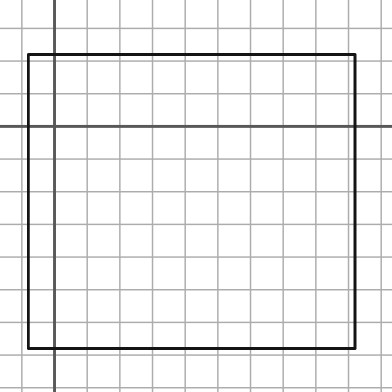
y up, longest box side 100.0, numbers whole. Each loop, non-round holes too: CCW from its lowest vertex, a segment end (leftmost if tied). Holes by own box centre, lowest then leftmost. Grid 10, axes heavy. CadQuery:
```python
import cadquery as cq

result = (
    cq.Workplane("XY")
    .moveTo(-8.0, -68.0)
    .lineTo(92.0, -68.0)
    .lineTo(92.0, 22.0)
    .lineTo(-8.0, 22.0)
    .close()
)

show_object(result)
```